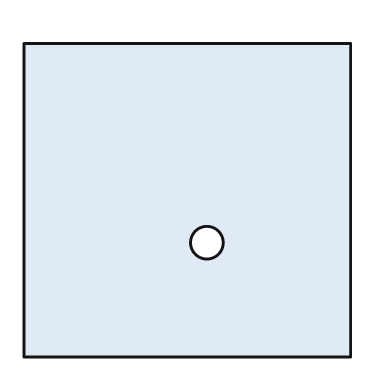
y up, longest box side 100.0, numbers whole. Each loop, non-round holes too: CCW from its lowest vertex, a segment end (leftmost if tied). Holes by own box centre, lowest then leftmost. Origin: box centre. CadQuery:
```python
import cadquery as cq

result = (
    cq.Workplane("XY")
    .moveTo(-50.0, -48.0)
    .lineTo(50.0, -48.0)
    .lineTo(50.0, 48.0)
    .lineTo(-50.0, 48.0)
    .close()
    .moveTo(6.0, -13.0)
    .circle(5.0)
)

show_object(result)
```